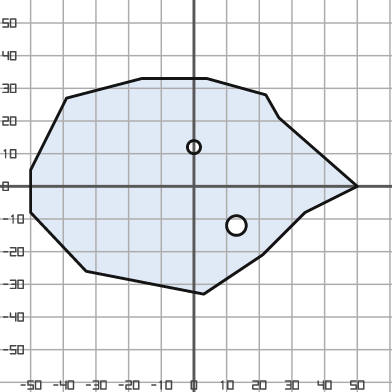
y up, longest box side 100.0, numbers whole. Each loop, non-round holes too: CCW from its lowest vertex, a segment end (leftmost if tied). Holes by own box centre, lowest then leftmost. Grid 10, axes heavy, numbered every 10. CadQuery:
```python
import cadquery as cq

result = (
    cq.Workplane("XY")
    .moveTo(3.0, -33.0)
    .lineTo(21.0, -21.0)
    .lineTo(34.0, -8.0)
    .lineTo(50.0, 0.0)
    .lineTo(26.0, 21.0)
    .lineTo(22.0, 28.0)
    .lineTo(4.0, 33.0)
    .lineTo(-16.0, 33.0)
    .lineTo(-39.0, 27.0)
    .lineTo(-50.0, 5.0)
    .lineTo(-50.0, -8.0)
    .lineTo(-33.0, -26.0)
    .close()
    .moveTo(13.0, -12.0)
    .circle(3.0)
    .moveTo(0.0, 12.0)
    .circle(2.0)
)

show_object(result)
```